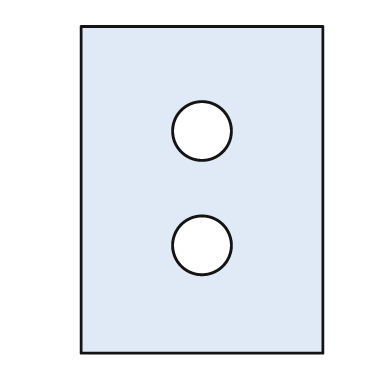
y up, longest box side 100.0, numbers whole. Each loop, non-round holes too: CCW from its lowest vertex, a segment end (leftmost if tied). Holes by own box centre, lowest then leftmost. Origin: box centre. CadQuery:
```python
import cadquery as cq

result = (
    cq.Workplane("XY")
    .moveTo(-37.0, -50.0)
    .lineTo(37.0, -50.0)
    .lineTo(37.0, 50.0)
    .lineTo(-37.0, 50.0)
    .close()
    .moveTo(0.0, -17.0)
    .circle(9.0)
    .moveTo(0.0, 18.0)
    .circle(9.0)
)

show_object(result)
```